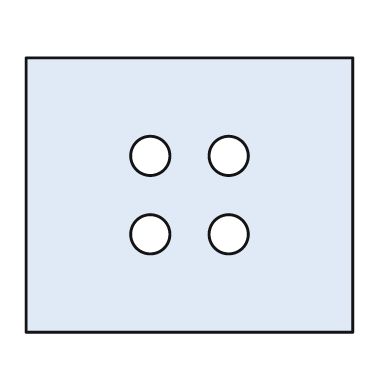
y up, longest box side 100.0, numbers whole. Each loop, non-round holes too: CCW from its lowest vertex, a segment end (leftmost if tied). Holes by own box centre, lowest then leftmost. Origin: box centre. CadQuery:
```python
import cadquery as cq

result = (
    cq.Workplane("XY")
    .moveTo(-50.0, -42.0)
    .lineTo(50.0, -42.0)
    .lineTo(50.0, 42.0)
    .lineTo(-50.0, 42.0)
    .close()
    .moveTo(-12.0, -12.0)
    .circle(6.0)
    .moveTo(12.0, -12.0)
    .circle(6.0)
    .moveTo(-12.0, 12.0)
    .circle(6.0)
    .moveTo(12.0, 12.0)
    .circle(6.0)
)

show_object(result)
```